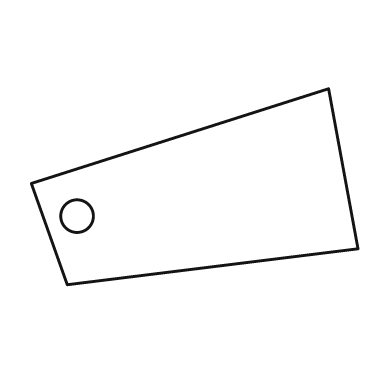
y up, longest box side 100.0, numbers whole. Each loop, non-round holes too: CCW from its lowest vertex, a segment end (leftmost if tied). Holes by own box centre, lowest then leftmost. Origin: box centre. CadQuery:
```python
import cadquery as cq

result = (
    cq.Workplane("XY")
    .moveTo(-39.0, -30.0)
    .lineTo(50.0, -19.0)
    .lineTo(41.0, 30.0)
    .lineTo(-50.0, 1.0)
    .close()
    .moveTo(-36.0, -9.0)
    .circle(5.0)
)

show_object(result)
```